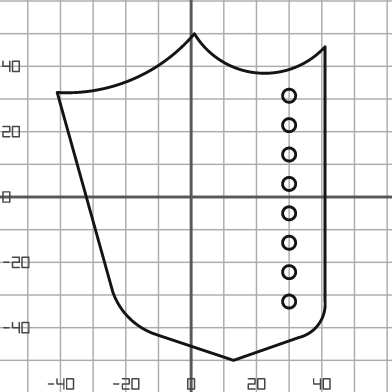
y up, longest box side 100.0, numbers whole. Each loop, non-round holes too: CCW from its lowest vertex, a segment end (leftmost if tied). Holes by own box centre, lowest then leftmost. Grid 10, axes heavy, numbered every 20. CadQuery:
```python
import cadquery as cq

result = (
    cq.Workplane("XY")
    .moveTo(13.0, -50.0)
    .lineTo(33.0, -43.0)
    .threePointArc((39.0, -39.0), (41.0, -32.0))
    .lineTo(41.0, 46.0)
    .threePointArc((20.0, 38.0), (1.0, 50.0))
    .threePointArc((-18.0, 36.0), (-41.0, 32.0))
    .lineTo(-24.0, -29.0)
    .threePointArc((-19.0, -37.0), (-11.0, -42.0))
    .close()
    .moveTo(30.0, -32.0)
    .circle(2.0)
    .moveTo(30.0, -23.0)
    .circle(2.0)
    .moveTo(30.0, -14.0)
    .circle(2.0)
    .moveTo(30.0, -5.0)
    .circle(2.0)
    .moveTo(30.0, 4.0)
    .circle(2.0)
    .moveTo(30.0, 13.0)
    .circle(2.0)
    .moveTo(30.0, 22.0)
    .circle(2.0)
    .moveTo(30.0, 31.0)
    .circle(2.0)
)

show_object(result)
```